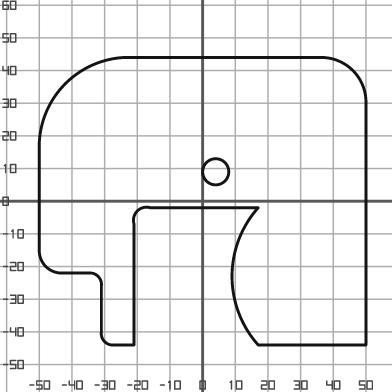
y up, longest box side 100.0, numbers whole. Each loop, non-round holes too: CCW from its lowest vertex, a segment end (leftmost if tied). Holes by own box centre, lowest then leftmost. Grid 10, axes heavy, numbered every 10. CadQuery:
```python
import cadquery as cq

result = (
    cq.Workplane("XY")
    .moveTo(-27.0, -44.0)
    .lineTo(-21.0, -44.0)
    .lineTo(-21.0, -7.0)
    .threePointArc((-20.0, -3.0), (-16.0, -2.0))
    .lineTo(17.0, -2.0)
    .threePointArc((9.0, -23.0), (17.0, -44.0))
    .lineTo(50.0, -44.0)
    .lineTo(50.0, 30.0)
    .threePointArc((46.0, 40.0), (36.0, 44.0))
    .lineTo(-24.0, 44.0)
    .threePointArc((-42.0, 36.0), (-50.0, 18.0))
    .lineTo(-50.0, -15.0)
    .threePointArc((-48.0, -20.0), (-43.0, -22.0))
    .lineTo(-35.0, -22.0)
    .threePointArc((-32.0, -23.0), (-31.0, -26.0))
    .lineTo(-31.0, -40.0)
    .threePointArc((-30.0, -43.0), (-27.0, -44.0))
    .close()
    .moveTo(4.0, 9.0)
    .circle(4.0)
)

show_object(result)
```